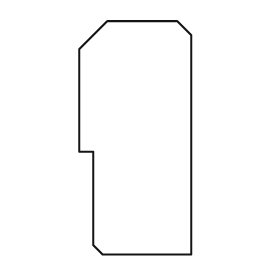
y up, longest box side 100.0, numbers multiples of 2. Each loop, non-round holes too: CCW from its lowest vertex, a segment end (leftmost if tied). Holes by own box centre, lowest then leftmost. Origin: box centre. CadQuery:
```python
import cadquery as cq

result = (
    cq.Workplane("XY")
    .moveTo(-14.0, -50.0)
    .lineTo(24.0, -50.0)
    .lineTo(24.0, 44.0)
    .lineTo(18.0, 50.0)
    .lineTo(-12.0, 50.0)
    .lineTo(-24.0, 38.0)
    .lineTo(-24.0, -6.0)
    .lineTo(-18.0, -6.0)
    .lineTo(-18.0, -46.0)
    .close()
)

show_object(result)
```